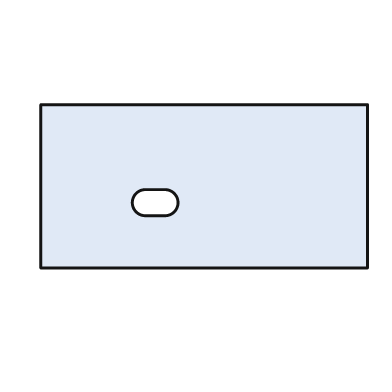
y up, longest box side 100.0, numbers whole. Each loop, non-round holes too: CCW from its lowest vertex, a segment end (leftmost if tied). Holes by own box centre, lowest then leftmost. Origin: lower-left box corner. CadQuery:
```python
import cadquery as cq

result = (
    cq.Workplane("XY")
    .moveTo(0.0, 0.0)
    .lineTo(100.0, 0.0)
    .lineTo(100.0, 50.0)
    .lineTo(0.0, 50.0)
    .close()
    .moveTo(32.0, 16.0)
    .lineTo(38.0, 16.0)
    .threePointArc((42.0, 20.0), (38.0, 24.0))
    .lineTo(32.0, 24.0)
    .threePointArc((28.0, 20.0), (32.0, 16.0))
    .close()
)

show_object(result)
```